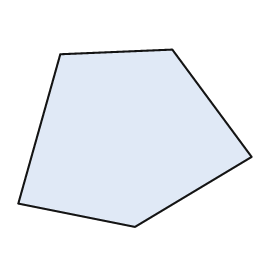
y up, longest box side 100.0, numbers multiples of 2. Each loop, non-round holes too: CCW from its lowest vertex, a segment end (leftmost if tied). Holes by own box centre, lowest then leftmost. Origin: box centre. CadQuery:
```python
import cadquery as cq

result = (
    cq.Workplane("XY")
    .moveTo(0.0, -38.0)
    .lineTo(50.0, -8.0)
    .lineTo(16.0, 38.0)
    .lineTo(-32.0, 36.0)
    .lineTo(-50.0, -28.0)
    .close()
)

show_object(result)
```